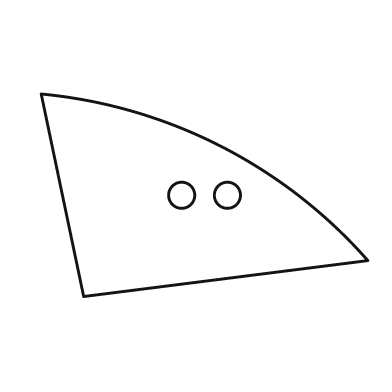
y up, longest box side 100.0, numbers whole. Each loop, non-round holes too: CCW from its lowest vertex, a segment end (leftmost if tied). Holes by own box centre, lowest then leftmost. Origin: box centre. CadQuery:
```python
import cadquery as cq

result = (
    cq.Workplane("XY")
    .moveTo(-37.0, -31.0)
    .lineTo(50.0, -20.0)
    .threePointArc((5.0, 15.0), (-50.0, 31.0))
    .close()
    .moveTo(-7.0, 0.0)
    .circle(4.0)
    .moveTo(7.0, 0.0)
    .circle(4.0)
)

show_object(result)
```